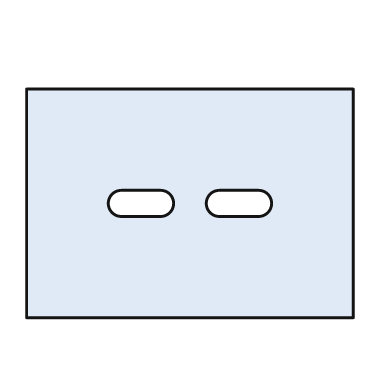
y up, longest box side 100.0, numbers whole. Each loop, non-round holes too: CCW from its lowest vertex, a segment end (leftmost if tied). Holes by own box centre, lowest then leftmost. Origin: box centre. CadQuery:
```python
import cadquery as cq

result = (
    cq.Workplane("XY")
    .moveTo(-50.0, -35.0)
    .lineTo(50.0, -35.0)
    .lineTo(50.0, 35.0)
    .lineTo(-50.0, 35.0)
    .close()
    .moveTo(-21.0, -4.0)
    .lineTo(-9.0, -4.0)
    .threePointArc((-5.0, 0.0), (-9.0, 4.0))
    .lineTo(-21.0, 4.0)
    .threePointArc((-25.0, 0.0), (-21.0, -4.0))
    .close()
    .moveTo(9.0, -4.0)
    .lineTo(21.0, -4.0)
    .threePointArc((25.0, 0.0), (21.0, 4.0))
    .lineTo(9.0, 4.0)
    .threePointArc((5.0, 0.0), (9.0, -4.0))
    .close()
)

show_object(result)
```